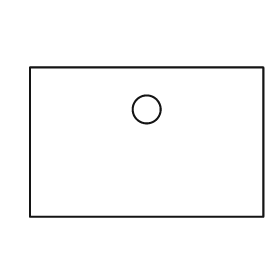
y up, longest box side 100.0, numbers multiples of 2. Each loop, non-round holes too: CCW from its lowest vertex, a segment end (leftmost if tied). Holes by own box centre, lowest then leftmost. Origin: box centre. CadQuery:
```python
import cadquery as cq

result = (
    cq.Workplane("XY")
    .moveTo(-50.0, -32.0)
    .lineTo(50.0, -32.0)
    .lineTo(50.0, 32.0)
    .lineTo(-50.0, 32.0)
    .close()
    .moveTo(0.0, 14.0)
    .circle(6.0)
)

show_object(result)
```